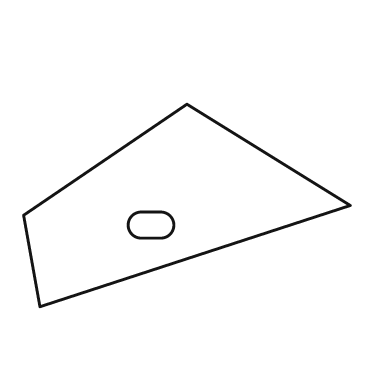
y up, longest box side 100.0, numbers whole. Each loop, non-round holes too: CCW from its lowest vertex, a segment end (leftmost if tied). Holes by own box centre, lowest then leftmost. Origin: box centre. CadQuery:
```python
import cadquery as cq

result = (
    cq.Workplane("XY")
    .moveTo(-45.0, -31.0)
    .lineTo(50.0, 0.0)
    .lineTo(0.0, 31.0)
    .lineTo(-50.0, -3.0)
    .close()
    .moveTo(-14.0, -10.0)
    .lineTo(-8.0, -10.0)
    .threePointArc((-4.0, -6.0), (-8.0, -2.0))
    .lineTo(-14.0, -2.0)
    .threePointArc((-18.0, -6.0), (-14.0, -10.0))
    .close()
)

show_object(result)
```